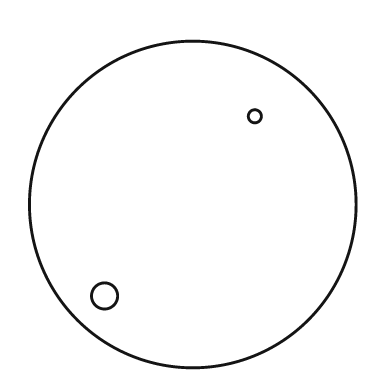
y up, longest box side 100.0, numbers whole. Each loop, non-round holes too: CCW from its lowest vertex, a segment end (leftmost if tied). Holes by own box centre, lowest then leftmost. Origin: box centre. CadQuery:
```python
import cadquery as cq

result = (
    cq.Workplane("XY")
    .moveTo(0.0, 0.0)
    .circle(50.0)
    .moveTo(-27.0, -28.0)
    .circle(4.0)
    .moveTo(19.0, 27.0)
    .circle(2.0)
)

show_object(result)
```